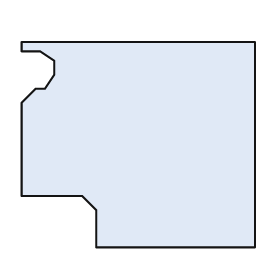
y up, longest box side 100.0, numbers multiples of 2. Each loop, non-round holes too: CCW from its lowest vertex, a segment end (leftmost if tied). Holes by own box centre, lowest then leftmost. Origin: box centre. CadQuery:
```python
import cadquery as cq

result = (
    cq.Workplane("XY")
    .moveTo(-18.0, -44.0)
    .lineTo(50.0, -44.0)
    .lineTo(50.0, 44.0)
    .lineTo(-50.0, 44.0)
    .lineTo(-50.0, 40.0)
    .lineTo(-42.0, 40.0)
    .lineTo(-36.0, 36.0)
    .lineTo(-36.0, 30.0)
    .lineTo(-40.0, 24.0)
    .lineTo(-44.0, 24.0)
    .lineTo(-50.0, 18.0)
    .lineTo(-50.0, -22.0)
    .lineTo(-24.0, -22.0)
    .lineTo(-18.0, -28.0)
    .close()
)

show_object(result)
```